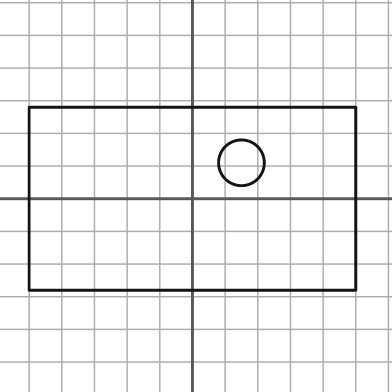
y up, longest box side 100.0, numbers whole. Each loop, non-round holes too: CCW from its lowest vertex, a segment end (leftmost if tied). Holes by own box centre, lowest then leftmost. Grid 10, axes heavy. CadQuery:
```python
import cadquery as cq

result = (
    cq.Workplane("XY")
    .moveTo(-50.0, -28.0)
    .lineTo(50.0, -28.0)
    .lineTo(50.0, 28.0)
    .lineTo(-50.0, 28.0)
    .close()
    .moveTo(15.0, 11.0)
    .circle(7.0)
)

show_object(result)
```